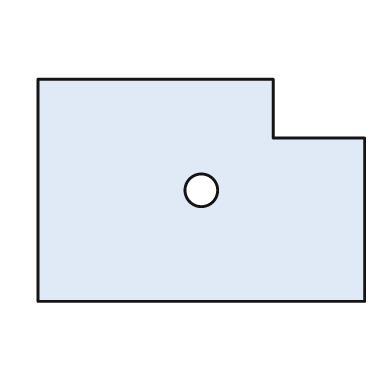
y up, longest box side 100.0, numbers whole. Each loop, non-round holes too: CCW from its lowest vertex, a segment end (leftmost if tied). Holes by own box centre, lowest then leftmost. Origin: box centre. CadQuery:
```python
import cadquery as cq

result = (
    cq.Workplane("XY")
    .moveTo(-50.0, -34.0)
    .lineTo(50.0, -34.0)
    .lineTo(50.0, 16.0)
    .lineTo(22.0, 16.0)
    .lineTo(22.0, 34.0)
    .lineTo(-50.0, 34.0)
    .close()
    .moveTo(0.0, 0.0)
    .circle(5.0)
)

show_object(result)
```